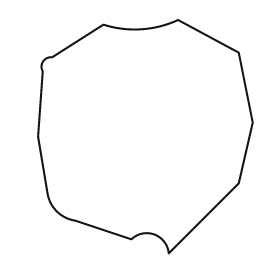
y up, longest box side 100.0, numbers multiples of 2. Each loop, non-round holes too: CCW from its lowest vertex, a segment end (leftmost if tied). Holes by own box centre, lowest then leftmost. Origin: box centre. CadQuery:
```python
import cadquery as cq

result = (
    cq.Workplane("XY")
    .moveTo(10.0, -50.0)
    .lineTo(40.0, -20.0)
    .lineTo(46.0, 6.0)
    .lineTo(40.0, 36.0)
    .lineTo(14.0, 50.0)
    .threePointArc((-2.0, 46.0), (-18.0, 48.0))
    .lineTo(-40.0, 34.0)
    .threePointArc((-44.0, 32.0), (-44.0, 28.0))
    .lineTo(-46.0, 0.0)
    .lineTo(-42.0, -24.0)
    .threePointArc((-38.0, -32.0), (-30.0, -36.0))
    .lineTo(-6.0, -44.0)
    .threePointArc((4.0, -42.0), (10.0, -50.0))
    .close()
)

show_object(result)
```